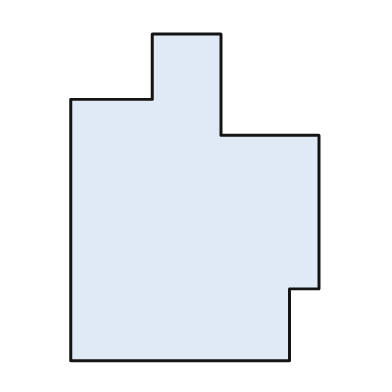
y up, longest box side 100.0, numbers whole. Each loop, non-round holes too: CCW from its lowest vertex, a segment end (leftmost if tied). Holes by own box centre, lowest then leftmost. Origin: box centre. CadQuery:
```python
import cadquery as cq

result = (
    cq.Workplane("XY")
    .moveTo(-38.0, -50.0)
    .lineTo(29.0, -50.0)
    .lineTo(29.0, -28.0)
    .lineTo(38.0, -28.0)
    .lineTo(38.0, 19.0)
    .lineTo(8.0, 19.0)
    .lineTo(8.0, 50.0)
    .lineTo(-13.0, 50.0)
    .lineTo(-13.0, 30.0)
    .lineTo(-38.0, 30.0)
    .close()
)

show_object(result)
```